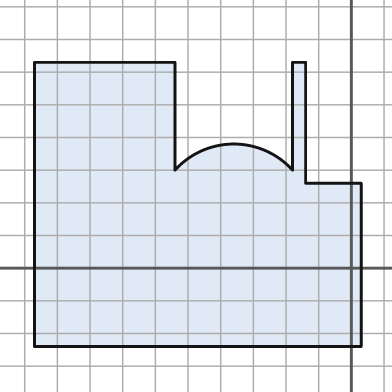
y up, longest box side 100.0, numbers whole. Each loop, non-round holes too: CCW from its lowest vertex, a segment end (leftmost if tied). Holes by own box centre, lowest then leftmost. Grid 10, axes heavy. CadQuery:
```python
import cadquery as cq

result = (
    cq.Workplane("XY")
    .moveTo(-97.0, -24.0)
    .lineTo(3.0, -24.0)
    .lineTo(3.0, 26.0)
    .lineTo(-14.0, 26.0)
    .lineTo(-14.0, 63.0)
    .lineTo(-18.0, 63.0)
    .lineTo(-18.0, 30.0)
    .threePointArc((-36.0, 38.0), (-54.0, 30.0))
    .lineTo(-54.0, 63.0)
    .lineTo(-97.0, 63.0)
    .close()
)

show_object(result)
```